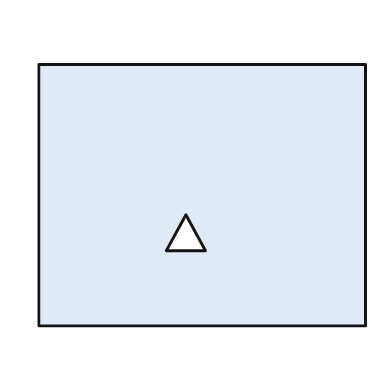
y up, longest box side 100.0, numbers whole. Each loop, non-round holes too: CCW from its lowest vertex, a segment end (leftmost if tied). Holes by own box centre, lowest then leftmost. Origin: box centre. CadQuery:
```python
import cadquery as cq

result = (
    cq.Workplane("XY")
    .moveTo(-50.0, -40.0)
    .lineTo(50.0, -40.0)
    .lineTo(50.0, 40.0)
    .lineTo(-50.0, 40.0)
    .close()
    .moveTo(-11.0, -17.0)
    .lineTo(1.0, -17.0)
    .lineTo(-5.0, -6.0)
    .close()
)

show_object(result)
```